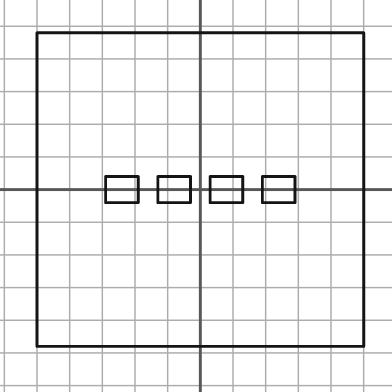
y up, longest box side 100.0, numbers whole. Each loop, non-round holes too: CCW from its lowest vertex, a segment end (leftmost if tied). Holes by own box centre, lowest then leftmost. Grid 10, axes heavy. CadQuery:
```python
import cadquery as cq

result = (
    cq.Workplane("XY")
    .moveTo(-50.0, -48.0)
    .lineTo(50.0, -48.0)
    .lineTo(50.0, 48.0)
    .lineTo(-50.0, 48.0)
    .close()
    .moveTo(-29.0, -4.0)
    .lineTo(-19.0, -4.0)
    .lineTo(-19.0, 4.0)
    .lineTo(-29.0, 4.0)
    .close()
    .moveTo(-13.0, -4.0)
    .lineTo(-3.0, -4.0)
    .lineTo(-3.0, 4.0)
    .lineTo(-13.0, 4.0)
    .close()
    .moveTo(3.0, -4.0)
    .lineTo(13.0, -4.0)
    .lineTo(13.0, 4.0)
    .lineTo(3.0, 4.0)
    .close()
    .moveTo(19.0, -4.0)
    .lineTo(29.0, -4.0)
    .lineTo(29.0, 4.0)
    .lineTo(19.0, 4.0)
    .close()
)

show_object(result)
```